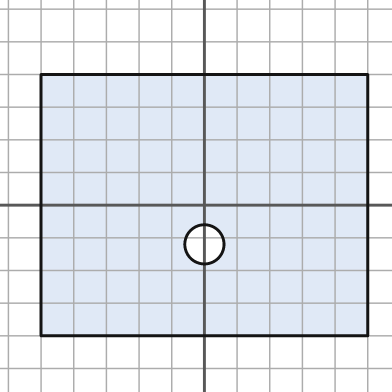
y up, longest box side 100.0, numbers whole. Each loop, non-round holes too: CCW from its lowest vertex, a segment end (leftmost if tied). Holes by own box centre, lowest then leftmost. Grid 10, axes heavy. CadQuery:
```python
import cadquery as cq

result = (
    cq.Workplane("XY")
    .moveTo(-50.0, -40.0)
    .lineTo(50.0, -40.0)
    .lineTo(50.0, 40.0)
    .lineTo(-50.0, 40.0)
    .close()
    .moveTo(0.0, -12.0)
    .circle(6.0)
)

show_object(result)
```